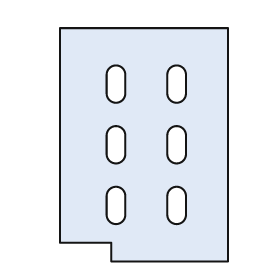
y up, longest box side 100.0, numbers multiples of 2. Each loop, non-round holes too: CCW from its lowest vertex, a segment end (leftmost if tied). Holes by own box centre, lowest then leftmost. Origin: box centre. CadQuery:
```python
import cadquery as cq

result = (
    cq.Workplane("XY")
    .moveTo(-14.0, -50.0)
    .lineTo(36.0, -50.0)
    .lineTo(36.0, 50.0)
    .lineTo(-36.0, 50.0)
    .lineTo(-36.0, -42.0)
    .lineTo(-14.0, -42.0)
    .close()
    .moveTo(-16.0, -30.0)
    .threePointArc((-12.0, -34.0), (-8.0, -30.0))
    .lineTo(-8.0, -22.0)
    .threePointArc((-12.0, -18.0), (-16.0, -22.0))
    .close()
    .moveTo(10.0, -30.0)
    .threePointArc((14.0, -34.0), (18.0, -30.0))
    .lineTo(18.0, -22.0)
    .threePointArc((14.0, -18.0), (10.0, -22.0))
    .close()
    .moveTo(-16.0, -4.0)
    .threePointArc((-12.0, -8.0), (-8.0, -4.0))
    .lineTo(-8.0, 4.0)
    .threePointArc((-12.0, 8.0), (-16.0, 4.0))
    .close()
    .moveTo(10.0, -4.0)
    .threePointArc((14.0, -8.0), (18.0, -4.0))
    .lineTo(18.0, 4.0)
    .threePointArc((14.0, 8.0), (10.0, 4.0))
    .close()
    .moveTo(-16.0, 22.0)
    .threePointArc((-12.0, 18.0), (-8.0, 22.0))
    .lineTo(-8.0, 30.0)
    .threePointArc((-12.0, 34.0), (-16.0, 30.0))
    .close()
    .moveTo(10.0, 22.0)
    .threePointArc((14.0, 18.0), (18.0, 22.0))
    .lineTo(18.0, 30.0)
    .threePointArc((14.0, 34.0), (10.0, 30.0))
    .close()
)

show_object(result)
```